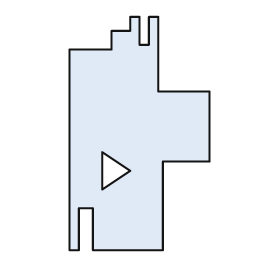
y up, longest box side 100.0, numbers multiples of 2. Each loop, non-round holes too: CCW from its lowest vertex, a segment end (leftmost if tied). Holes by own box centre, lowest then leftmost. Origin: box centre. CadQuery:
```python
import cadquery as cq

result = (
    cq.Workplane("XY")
    .moveTo(-30.0, -50.0)
    .lineTo(-26.0, -50.0)
    .lineTo(-26.0, -32.0)
    .lineTo(-20.0, -32.0)
    .lineTo(-20.0, -50.0)
    .lineTo(10.0, -50.0)
    .lineTo(10.0, -12.0)
    .lineTo(30.0, -12.0)
    .lineTo(30.0, 18.0)
    .lineTo(8.0, 18.0)
    .lineTo(8.0, 50.0)
    .lineTo(4.0, 50.0)
    .lineTo(4.0, 38.0)
    .lineTo(0.0, 38.0)
    .lineTo(0.0, 50.0)
    .lineTo(-4.0, 50.0)
    .lineTo(-4.0, 44.0)
    .lineTo(-12.0, 44.0)
    .lineTo(-12.0, 36.0)
    .lineTo(-30.0, 36.0)
    .close()
    .moveTo(-16.0, -24.0)
    .lineTo(-4.0, -16.0)
    .lineTo(-16.0, -8.0)
    .close()
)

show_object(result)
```